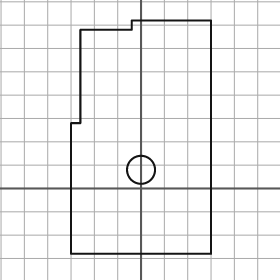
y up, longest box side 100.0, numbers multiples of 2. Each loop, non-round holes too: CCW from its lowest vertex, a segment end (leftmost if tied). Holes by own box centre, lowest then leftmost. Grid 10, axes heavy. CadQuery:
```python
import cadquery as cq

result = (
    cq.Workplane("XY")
    .moveTo(-30.0, -28.0)
    .lineTo(30.0, -28.0)
    .lineTo(30.0, 72.0)
    .lineTo(-4.0, 72.0)
    .lineTo(-4.0, 68.0)
    .lineTo(-26.0, 68.0)
    .lineTo(-26.0, 28.0)
    .lineTo(-30.0, 28.0)
    .close()
    .moveTo(0.0, 8.0)
    .circle(6.0)
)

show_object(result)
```